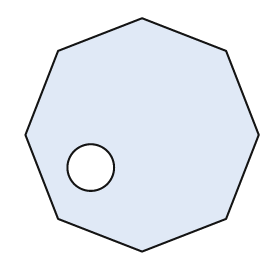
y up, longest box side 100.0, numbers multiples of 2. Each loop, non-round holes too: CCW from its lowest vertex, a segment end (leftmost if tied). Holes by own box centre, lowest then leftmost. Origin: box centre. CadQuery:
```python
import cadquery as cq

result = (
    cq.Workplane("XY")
    .moveTo(0.0, -50.0)
    .lineTo(36.0, -36.0)
    .lineTo(50.0, 0.0)
    .lineTo(36.0, 36.0)
    .lineTo(0.0, 50.0)
    .lineTo(-36.0, 36.0)
    .lineTo(-50.0, 0.0)
    .lineTo(-36.0, -36.0)
    .close()
    .moveTo(-22.0, -14.0)
    .circle(10.0)
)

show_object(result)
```